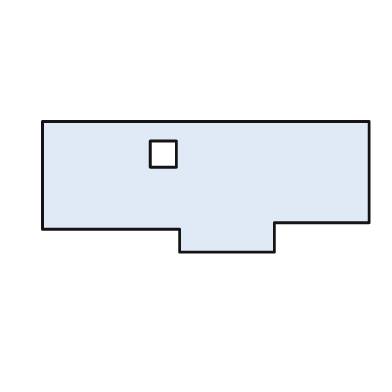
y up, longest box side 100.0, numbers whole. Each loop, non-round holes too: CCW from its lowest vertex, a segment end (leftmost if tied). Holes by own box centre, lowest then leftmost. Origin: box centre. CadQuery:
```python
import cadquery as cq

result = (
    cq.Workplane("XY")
    .moveTo(-8.0, -20.0)
    .lineTo(21.0, -20.0)
    .lineTo(21.0, -11.0)
    .lineTo(50.0, -11.0)
    .lineTo(50.0, 20.0)
    .lineTo(-50.0, 20.0)
    .lineTo(-50.0, -13.0)
    .lineTo(-8.0, -13.0)
    .close()
    .moveTo(-17.0, 6.0)
    .lineTo(-9.0, 6.0)
    .lineTo(-9.0, 14.0)
    .lineTo(-17.0, 14.0)
    .close()
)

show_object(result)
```